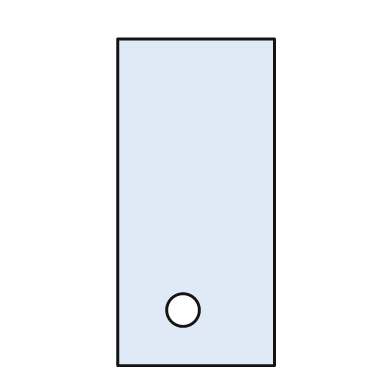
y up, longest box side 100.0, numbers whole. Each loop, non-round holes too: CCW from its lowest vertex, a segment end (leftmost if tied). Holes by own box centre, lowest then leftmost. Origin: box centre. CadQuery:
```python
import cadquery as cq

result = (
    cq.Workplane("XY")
    .moveTo(-24.0, -50.0)
    .lineTo(24.0, -50.0)
    .lineTo(24.0, 50.0)
    .lineTo(-24.0, 50.0)
    .close()
    .moveTo(-4.0, -33.0)
    .circle(5.0)
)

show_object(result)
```